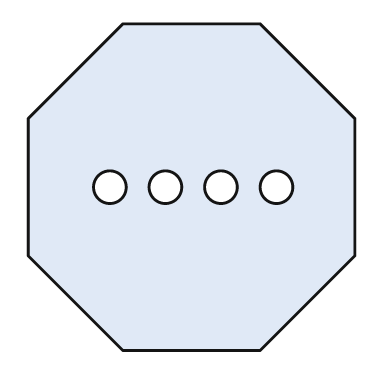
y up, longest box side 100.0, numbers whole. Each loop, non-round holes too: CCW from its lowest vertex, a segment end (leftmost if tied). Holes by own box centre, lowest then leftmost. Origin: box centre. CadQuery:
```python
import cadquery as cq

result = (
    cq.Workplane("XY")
    .moveTo(-21.0, -50.0)
    .lineTo(21.0, -50.0)
    .lineTo(50.0, -21.0)
    .lineTo(50.0, 21.0)
    .lineTo(21.0, 50.0)
    .lineTo(-21.0, 50.0)
    .lineTo(-50.0, 21.0)
    .lineTo(-50.0, -21.0)
    .close()
    .moveTo(-25.0, 0.0)
    .circle(5.0)
    .moveTo(-8.0, 0.0)
    .circle(5.0)
    .moveTo(9.0, 0.0)
    .circle(5.0)
    .moveTo(26.0, 0.0)
    .circle(5.0)
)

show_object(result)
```